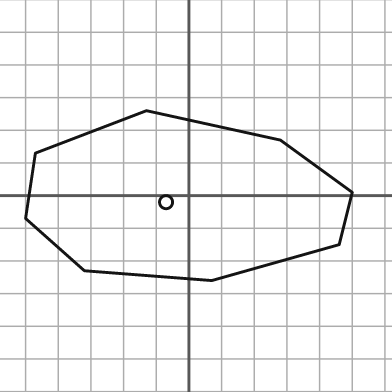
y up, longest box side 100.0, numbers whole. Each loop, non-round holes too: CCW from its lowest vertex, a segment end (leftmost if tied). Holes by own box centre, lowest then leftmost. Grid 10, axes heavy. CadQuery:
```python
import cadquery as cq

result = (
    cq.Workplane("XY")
    .moveTo(7.0, -26.0)
    .lineTo(46.0, -15.0)
    .lineTo(50.0, 1.0)
    .lineTo(28.0, 17.0)
    .lineTo(-13.0, 26.0)
    .lineTo(-47.0, 13.0)
    .lineTo(-50.0, -7.0)
    .lineTo(-32.0, -23.0)
    .close()
    .moveTo(-7.0, -2.0)
    .circle(2.0)
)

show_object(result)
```